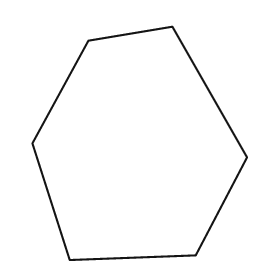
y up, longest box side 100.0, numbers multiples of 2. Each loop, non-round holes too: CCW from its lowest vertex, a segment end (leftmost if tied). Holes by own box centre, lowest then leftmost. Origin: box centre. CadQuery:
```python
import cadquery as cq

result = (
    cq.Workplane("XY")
    .moveTo(-30.0, -50.0)
    .lineTo(24.0, -48.0)
    .lineTo(46.0, -6.0)
    .lineTo(14.0, 50.0)
    .lineTo(-22.0, 44.0)
    .lineTo(-46.0, 0.0)
    .close()
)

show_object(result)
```